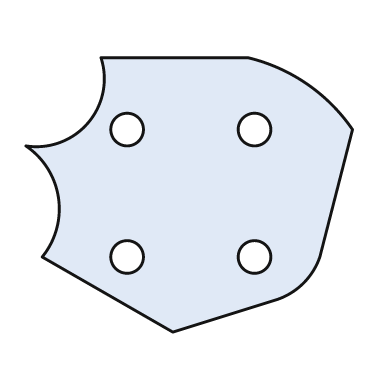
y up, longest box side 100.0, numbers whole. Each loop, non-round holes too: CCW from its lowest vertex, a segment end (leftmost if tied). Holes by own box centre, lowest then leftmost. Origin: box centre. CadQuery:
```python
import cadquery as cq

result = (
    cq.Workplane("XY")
    .moveTo(-5.0, -42.0)
    .lineTo(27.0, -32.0)
    .threePointArc((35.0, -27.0), (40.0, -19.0))
    .lineTo(50.0, 20.0)
    .threePointArc((36.0, 34.0), (18.0, 42.0))
    .lineTo(-27.0, 42.0)
    .threePointArc((-31.0, 22.0), (-50.0, 15.0))
    .threePointArc((-40.0, -1.0), (-45.0, -19.0))
    .close()
    .moveTo(-19.0, -19.0)
    .circle(5.0)
    .moveTo(20.0, -19.0)
    .circle(5.0)
    .moveTo(-19.0, 20.0)
    .circle(5.0)
    .moveTo(20.0, 20.0)
    .circle(5.0)
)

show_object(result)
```